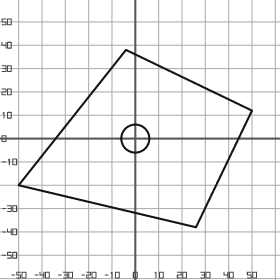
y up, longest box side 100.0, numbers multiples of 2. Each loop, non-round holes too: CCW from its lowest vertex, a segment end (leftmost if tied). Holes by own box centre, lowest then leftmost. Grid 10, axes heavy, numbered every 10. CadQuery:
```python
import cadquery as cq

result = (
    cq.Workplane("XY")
    .moveTo(26.0, -38.0)
    .lineTo(50.0, 12.0)
    .lineTo(-4.0, 38.0)
    .lineTo(-50.0, -20.0)
    .close()
    .moveTo(0.0, 0.0)
    .circle(6.0)
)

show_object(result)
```